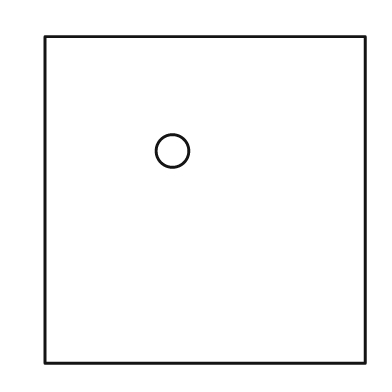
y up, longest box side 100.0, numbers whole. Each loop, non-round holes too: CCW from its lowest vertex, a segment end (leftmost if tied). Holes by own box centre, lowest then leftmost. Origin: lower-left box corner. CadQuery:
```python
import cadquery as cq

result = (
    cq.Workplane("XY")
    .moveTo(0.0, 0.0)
    .lineTo(98.0, 0.0)
    .lineTo(98.0, 100.0)
    .lineTo(0.0, 100.0)
    .close()
    .moveTo(39.0, 65.0)
    .circle(5.0)
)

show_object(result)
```